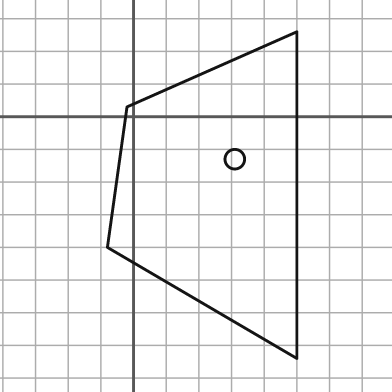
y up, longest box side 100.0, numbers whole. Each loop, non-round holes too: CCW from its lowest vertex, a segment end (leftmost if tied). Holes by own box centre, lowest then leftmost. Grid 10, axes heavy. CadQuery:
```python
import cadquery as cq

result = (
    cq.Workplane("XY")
    .moveTo(50.0, -74.0)
    .lineTo(50.0, 26.0)
    .lineTo(-2.0, 3.0)
    .lineTo(-8.0, -40.0)
    .close()
    .moveTo(31.0, -13.0)
    .circle(3.0)
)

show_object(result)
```